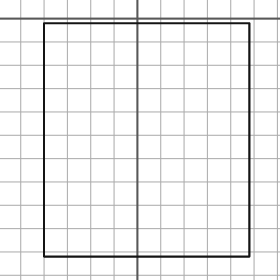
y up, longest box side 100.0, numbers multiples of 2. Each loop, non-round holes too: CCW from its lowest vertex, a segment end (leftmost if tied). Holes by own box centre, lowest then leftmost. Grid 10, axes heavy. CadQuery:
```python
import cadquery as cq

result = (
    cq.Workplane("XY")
    .moveTo(-40.0, -102.0)
    .lineTo(48.0, -102.0)
    .lineTo(48.0, -2.0)
    .lineTo(-40.0, -2.0)
    .close()
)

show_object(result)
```